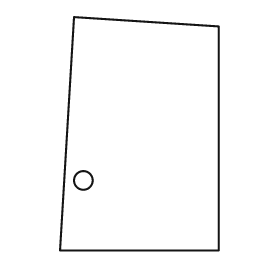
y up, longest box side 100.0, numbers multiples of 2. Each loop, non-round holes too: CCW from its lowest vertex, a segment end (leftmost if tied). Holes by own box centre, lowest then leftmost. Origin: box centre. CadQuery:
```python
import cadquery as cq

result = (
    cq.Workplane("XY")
    .moveTo(-34.0, -50.0)
    .lineTo(34.0, -50.0)
    .lineTo(34.0, 46.0)
    .lineTo(-28.0, 50.0)
    .close()
    .moveTo(-24.0, -20.0)
    .circle(4.0)
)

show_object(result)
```